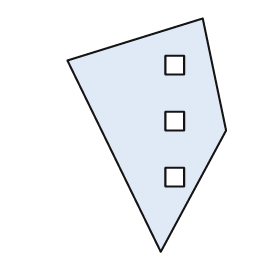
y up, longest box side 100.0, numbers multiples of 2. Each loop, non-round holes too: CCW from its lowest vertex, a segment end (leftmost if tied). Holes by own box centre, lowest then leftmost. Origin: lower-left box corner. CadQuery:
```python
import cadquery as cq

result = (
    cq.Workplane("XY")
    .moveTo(40.0, 0.0)
    .lineTo(68.0, 52.0)
    .lineTo(58.0, 100.0)
    .lineTo(0.0, 82.0)
    .close()
    .moveTo(42.0, 28.0)
    .lineTo(50.0, 28.0)
    .lineTo(50.0, 36.0)
    .lineTo(42.0, 36.0)
    .close()
    .moveTo(42.0, 52.0)
    .lineTo(50.0, 52.0)
    .lineTo(50.0, 60.0)
    .lineTo(42.0, 60.0)
    .close()
    .moveTo(42.0, 76.0)
    .lineTo(50.0, 76.0)
    .lineTo(50.0, 84.0)
    .lineTo(42.0, 84.0)
    .close()
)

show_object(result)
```